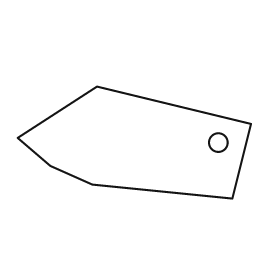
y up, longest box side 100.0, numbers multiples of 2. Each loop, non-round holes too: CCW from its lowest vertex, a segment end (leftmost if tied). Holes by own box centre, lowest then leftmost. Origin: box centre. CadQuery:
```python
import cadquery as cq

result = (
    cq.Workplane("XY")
    .moveTo(42.0, -24.0)
    .lineTo(50.0, 8.0)
    .lineTo(-16.0, 24.0)
    .lineTo(-50.0, 2.0)
    .lineTo(-36.0, -10.0)
    .lineTo(-18.0, -18.0)
    .close()
    .moveTo(36.0, 0.0)
    .circle(4.0)
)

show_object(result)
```